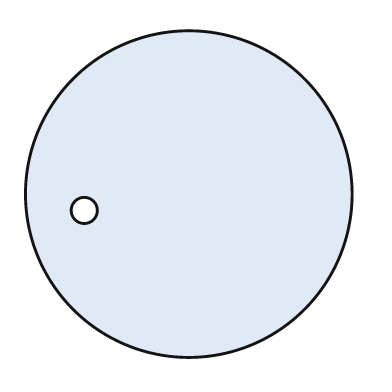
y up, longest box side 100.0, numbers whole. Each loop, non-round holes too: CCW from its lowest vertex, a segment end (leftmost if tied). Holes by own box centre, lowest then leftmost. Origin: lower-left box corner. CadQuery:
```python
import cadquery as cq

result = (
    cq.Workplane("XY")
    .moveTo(50.0, 50.0)
    .circle(50.0)
    .moveTo(18.0, 45.0)
    .circle(4.0)
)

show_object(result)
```